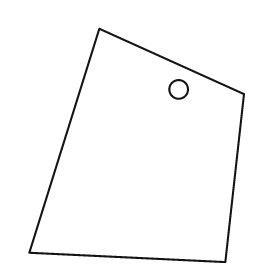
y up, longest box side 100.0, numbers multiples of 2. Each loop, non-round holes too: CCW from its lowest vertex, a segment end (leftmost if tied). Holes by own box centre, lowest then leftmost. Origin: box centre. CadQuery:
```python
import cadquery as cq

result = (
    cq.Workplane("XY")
    .moveTo(38.0, -50.0)
    .lineTo(46.0, 22.0)
    .lineTo(-16.0, 50.0)
    .lineTo(-46.0, -46.0)
    .close()
    .moveTo(18.0, 24.0)
    .circle(4.0)
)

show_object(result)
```